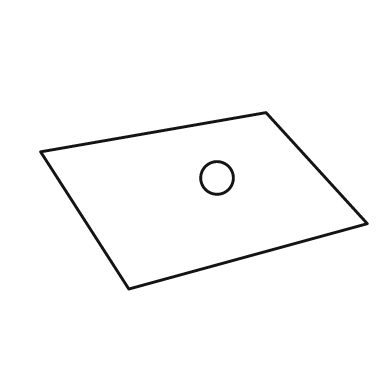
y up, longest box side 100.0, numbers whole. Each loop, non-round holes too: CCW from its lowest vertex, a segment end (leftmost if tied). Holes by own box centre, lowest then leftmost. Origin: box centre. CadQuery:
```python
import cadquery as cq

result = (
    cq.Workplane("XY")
    .moveTo(-23.0, -27.0)
    .lineTo(50.0, -7.0)
    .lineTo(19.0, 27.0)
    .lineTo(-50.0, 15.0)
    .close()
    .moveTo(4.0, 7.0)
    .circle(5.0)
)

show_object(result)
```